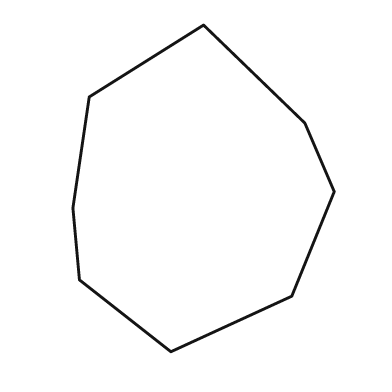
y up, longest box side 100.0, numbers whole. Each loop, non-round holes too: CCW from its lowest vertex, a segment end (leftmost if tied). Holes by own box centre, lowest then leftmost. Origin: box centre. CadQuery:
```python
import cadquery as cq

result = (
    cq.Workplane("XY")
    .moveTo(-10.0, -50.0)
    .lineTo(27.0, -33.0)
    .lineTo(40.0, -1.0)
    .lineTo(31.0, 20.0)
    .lineTo(0.0, 50.0)
    .lineTo(-35.0, 28.0)
    .lineTo(-40.0, -6.0)
    .lineTo(-38.0, -28.0)
    .close()
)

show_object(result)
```